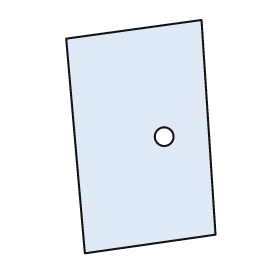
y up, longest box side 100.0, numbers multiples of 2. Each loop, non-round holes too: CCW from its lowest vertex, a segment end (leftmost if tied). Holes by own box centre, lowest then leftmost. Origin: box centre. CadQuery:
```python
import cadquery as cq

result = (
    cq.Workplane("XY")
    .moveTo(-24.0, -50.0)
    .lineTo(32.0, -42.0)
    .lineTo(26.0, 50.0)
    .lineTo(-32.0, 42.0)
    .close()
    .moveTo(10.0, 0.0)
    .circle(4.0)
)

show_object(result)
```